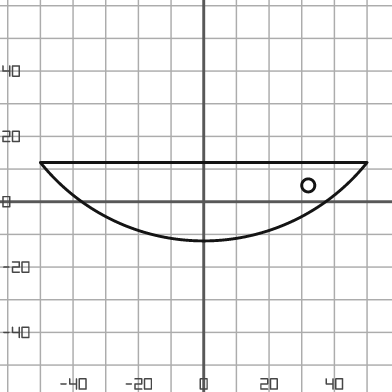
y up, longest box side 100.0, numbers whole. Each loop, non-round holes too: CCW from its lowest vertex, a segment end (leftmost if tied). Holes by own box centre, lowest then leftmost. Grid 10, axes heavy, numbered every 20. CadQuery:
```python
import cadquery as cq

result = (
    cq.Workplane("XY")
    .moveTo(-50.0, 12.0)
    .threePointArc((0.0, -12.0), (50.0, 12.0))
    .close()
    .moveTo(32.0, 5.0)
    .circle(2.0)
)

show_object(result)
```